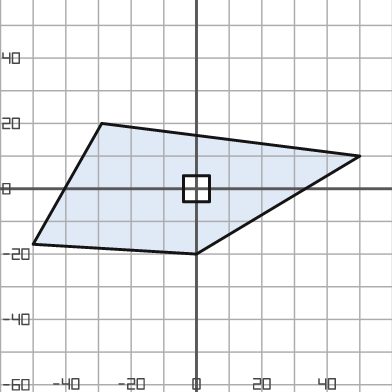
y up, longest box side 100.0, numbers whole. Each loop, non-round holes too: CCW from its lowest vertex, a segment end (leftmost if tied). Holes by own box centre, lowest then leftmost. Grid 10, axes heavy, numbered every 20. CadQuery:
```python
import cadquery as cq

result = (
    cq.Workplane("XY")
    .moveTo(0.0, -20.0)
    .lineTo(50.0, 10.0)
    .lineTo(-29.0, 20.0)
    .lineTo(-50.0, -17.0)
    .close()
    .moveTo(-4.0, -4.0)
    .lineTo(4.0, -4.0)
    .lineTo(4.0, 4.0)
    .lineTo(-4.0, 4.0)
    .close()
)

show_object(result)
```